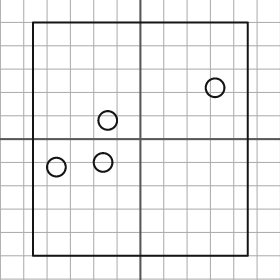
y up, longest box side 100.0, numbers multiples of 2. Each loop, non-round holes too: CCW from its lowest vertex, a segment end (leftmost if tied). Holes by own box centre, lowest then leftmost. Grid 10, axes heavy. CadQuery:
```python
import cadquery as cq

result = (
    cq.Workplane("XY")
    .moveTo(-46.0, -50.0)
    .lineTo(46.0, -50.0)
    .lineTo(46.0, 50.0)
    .lineTo(-46.0, 50.0)
    .close()
    .moveTo(-36.0, -12.0)
    .circle(4.0)
    .moveTo(-16.0, -10.0)
    .circle(4.0)
    .moveTo(-14.0, 8.0)
    .circle(4.0)
    .moveTo(32.0, 22.0)
    .circle(4.0)
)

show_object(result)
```